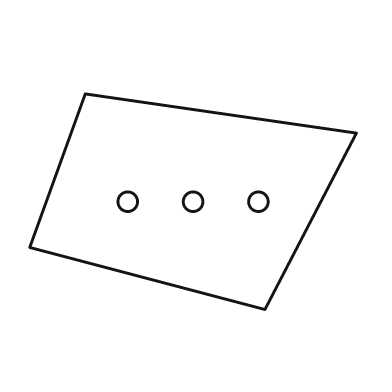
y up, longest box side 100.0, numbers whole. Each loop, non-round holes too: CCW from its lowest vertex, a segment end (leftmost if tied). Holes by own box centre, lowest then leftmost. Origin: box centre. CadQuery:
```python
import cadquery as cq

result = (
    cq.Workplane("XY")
    .moveTo(22.0, -33.0)
    .lineTo(50.0, 21.0)
    .lineTo(-33.0, 33.0)
    .lineTo(-50.0, -14.0)
    .close()
    .moveTo(-20.0, 0.0)
    .circle(3.0)
    .moveTo(0.0, 0.0)
    .circle(3.0)
    .moveTo(20.0, 0.0)
    .circle(3.0)
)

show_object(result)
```